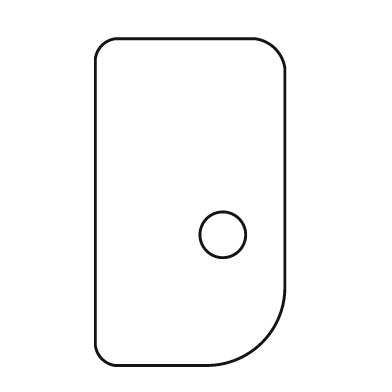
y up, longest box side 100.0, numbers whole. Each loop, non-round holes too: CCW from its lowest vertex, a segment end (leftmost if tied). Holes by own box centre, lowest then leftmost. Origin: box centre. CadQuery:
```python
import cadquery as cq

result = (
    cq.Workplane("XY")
    .moveTo(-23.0, -50.0)
    .lineTo(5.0, -50.0)
    .threePointArc((22.0, -43.0), (29.0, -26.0))
    .lineTo(29.0, 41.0)
    .threePointArc((26.0, 47.0), (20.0, 50.0))
    .lineTo(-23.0, 50.0)
    .threePointArc((-27.0, 48.0), (-29.0, 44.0))
    .lineTo(-29.0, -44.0)
    .threePointArc((-27.0, -48.0), (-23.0, -50.0))
    .close()
    .moveTo(10.0, -10.0)
    .circle(7.0)
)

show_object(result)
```